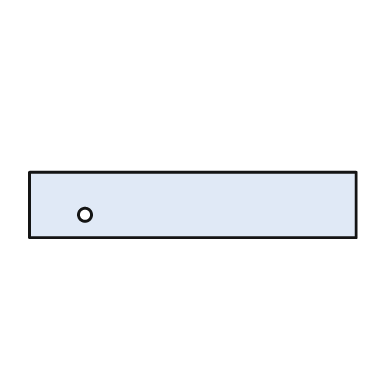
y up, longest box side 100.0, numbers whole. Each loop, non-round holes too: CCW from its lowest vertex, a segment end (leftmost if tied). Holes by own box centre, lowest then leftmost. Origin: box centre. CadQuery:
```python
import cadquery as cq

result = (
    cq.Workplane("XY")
    .moveTo(-50.0, -10.0)
    .lineTo(50.0, -10.0)
    .lineTo(50.0, 10.0)
    .lineTo(-50.0, 10.0)
    .close()
    .moveTo(-33.0, -3.0)
    .circle(2.0)
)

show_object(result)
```